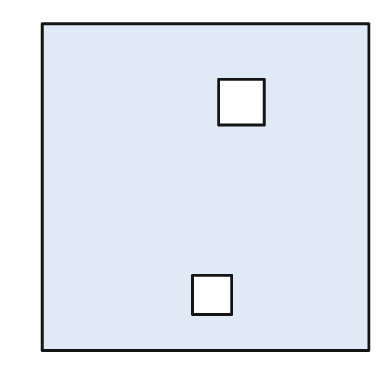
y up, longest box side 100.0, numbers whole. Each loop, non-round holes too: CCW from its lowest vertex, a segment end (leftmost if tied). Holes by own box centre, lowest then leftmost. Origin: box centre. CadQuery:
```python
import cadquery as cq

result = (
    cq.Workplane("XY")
    .moveTo(-50.0, -50.0)
    .lineTo(50.0, -50.0)
    .lineTo(50.0, 50.0)
    .lineTo(-50.0, 50.0)
    .close()
    .moveTo(-4.0, -39.0)
    .lineTo(8.0, -39.0)
    .lineTo(8.0, -27.0)
    .lineTo(-4.0, -27.0)
    .close()
    .moveTo(4.0, 19.0)
    .lineTo(18.0, 19.0)
    .lineTo(18.0, 33.0)
    .lineTo(4.0, 33.0)
    .close()
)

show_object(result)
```